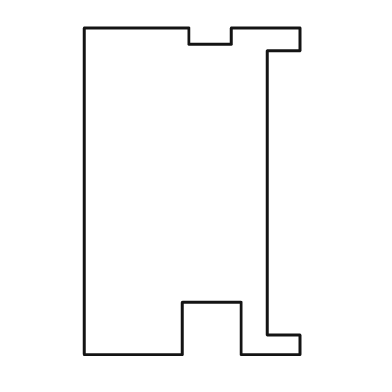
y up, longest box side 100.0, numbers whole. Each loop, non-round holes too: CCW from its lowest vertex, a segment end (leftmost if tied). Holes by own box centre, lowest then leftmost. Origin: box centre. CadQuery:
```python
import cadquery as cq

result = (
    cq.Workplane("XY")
    .moveTo(-33.0, -50.0)
    .lineTo(-3.0, -50.0)
    .lineTo(-3.0, -34.0)
    .lineTo(15.0, -34.0)
    .lineTo(15.0, -50.0)
    .lineTo(33.0, -50.0)
    .lineTo(33.0, -44.0)
    .lineTo(23.0, -44.0)
    .lineTo(23.0, 43.0)
    .lineTo(33.0, 43.0)
    .lineTo(33.0, 50.0)
    .lineTo(12.0, 50.0)
    .lineTo(12.0, 45.0)
    .lineTo(-1.0, 45.0)
    .lineTo(-1.0, 50.0)
    .lineTo(-33.0, 50.0)
    .close()
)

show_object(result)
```